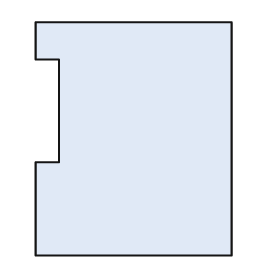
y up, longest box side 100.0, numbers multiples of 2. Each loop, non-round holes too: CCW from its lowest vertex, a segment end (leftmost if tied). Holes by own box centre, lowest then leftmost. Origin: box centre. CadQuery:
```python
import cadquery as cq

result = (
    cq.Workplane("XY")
    .moveTo(-42.0, -50.0)
    .lineTo(42.0, -50.0)
    .lineTo(42.0, 50.0)
    .lineTo(-42.0, 50.0)
    .lineTo(-42.0, 34.0)
    .lineTo(-32.0, 34.0)
    .lineTo(-32.0, -10.0)
    .lineTo(-42.0, -10.0)
    .close()
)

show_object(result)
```